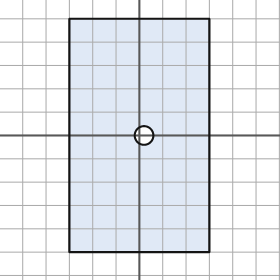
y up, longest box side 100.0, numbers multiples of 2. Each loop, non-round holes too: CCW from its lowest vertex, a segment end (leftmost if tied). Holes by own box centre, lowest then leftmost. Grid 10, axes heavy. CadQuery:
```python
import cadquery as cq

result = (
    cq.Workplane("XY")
    .moveTo(-30.0, -50.0)
    .lineTo(30.0, -50.0)
    .lineTo(30.0, 50.0)
    .lineTo(-30.0, 50.0)
    .close()
    .moveTo(2.0, 0.0)
    .circle(4.0)
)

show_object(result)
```